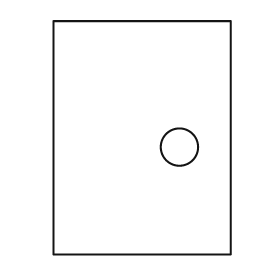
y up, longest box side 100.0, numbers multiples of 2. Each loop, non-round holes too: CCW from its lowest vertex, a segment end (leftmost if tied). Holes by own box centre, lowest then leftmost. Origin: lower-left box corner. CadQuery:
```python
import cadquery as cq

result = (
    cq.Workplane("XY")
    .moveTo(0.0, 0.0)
    .lineTo(76.0, 0.0)
    .lineTo(76.0, 100.0)
    .lineTo(0.0, 100.0)
    .close()
    .moveTo(54.0, 46.0)
    .circle(8.0)
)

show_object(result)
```